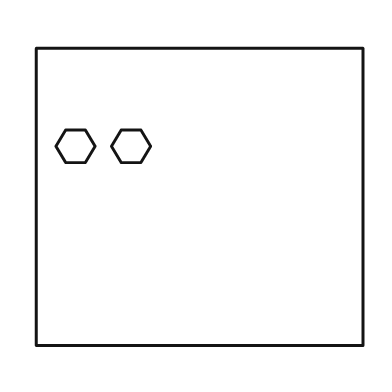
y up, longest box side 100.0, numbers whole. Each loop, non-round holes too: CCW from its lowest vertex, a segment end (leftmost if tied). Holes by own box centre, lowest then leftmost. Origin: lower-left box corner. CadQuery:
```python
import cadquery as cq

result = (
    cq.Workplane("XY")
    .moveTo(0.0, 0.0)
    .lineTo(100.0, 0.0)
    .lineTo(100.0, 91.0)
    .lineTo(0.0, 91.0)
    .close()
    .moveTo(9.0, 56.0)
    .lineTo(15.0, 56.0)
    .lineTo(18.0, 61.0)
    .lineTo(15.0, 66.0)
    .lineTo(9.0, 66.0)
    .lineTo(6.0, 61.0)
    .close()
    .moveTo(26.0, 56.0)
    .lineTo(32.0, 56.0)
    .lineTo(35.0, 61.0)
    .lineTo(32.0, 66.0)
    .lineTo(26.0, 66.0)
    .lineTo(23.0, 61.0)
    .close()
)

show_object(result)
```